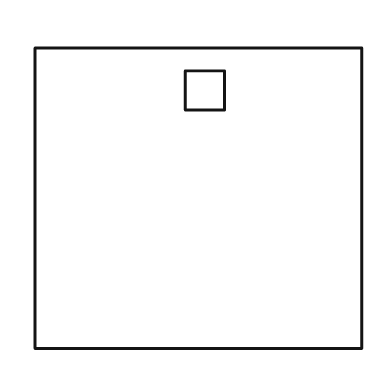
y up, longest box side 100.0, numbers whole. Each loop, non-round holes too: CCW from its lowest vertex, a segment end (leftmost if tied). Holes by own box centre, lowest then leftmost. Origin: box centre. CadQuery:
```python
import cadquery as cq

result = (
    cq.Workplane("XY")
    .moveTo(-50.0, -46.0)
    .lineTo(50.0, -46.0)
    .lineTo(50.0, 46.0)
    .lineTo(-50.0, 46.0)
    .close()
    .moveTo(-4.0, 27.0)
    .lineTo(8.0, 27.0)
    .lineTo(8.0, 39.0)
    .lineTo(-4.0, 39.0)
    .close()
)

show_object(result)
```